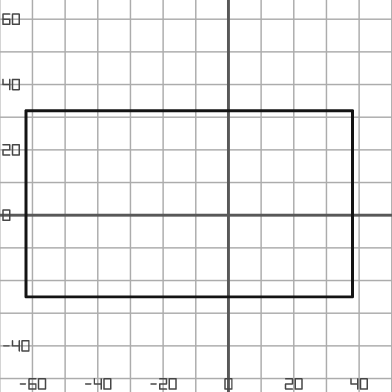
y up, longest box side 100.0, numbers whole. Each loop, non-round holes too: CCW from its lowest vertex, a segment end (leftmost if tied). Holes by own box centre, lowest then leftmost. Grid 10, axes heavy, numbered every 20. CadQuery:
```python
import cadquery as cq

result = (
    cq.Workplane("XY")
    .moveTo(-62.0, -25.0)
    .lineTo(38.0, -25.0)
    .lineTo(38.0, 32.0)
    .lineTo(-62.0, 32.0)
    .close()
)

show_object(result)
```